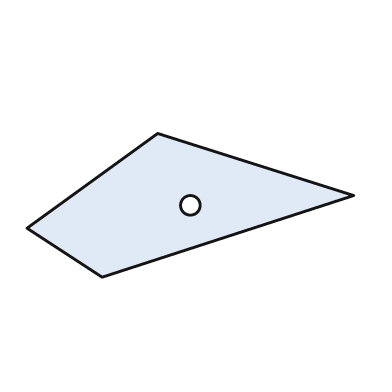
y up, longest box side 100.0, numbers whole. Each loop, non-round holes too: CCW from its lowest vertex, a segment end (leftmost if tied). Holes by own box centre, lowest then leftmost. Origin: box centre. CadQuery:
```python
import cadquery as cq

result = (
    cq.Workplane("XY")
    .moveTo(-27.0, -22.0)
    .lineTo(50.0, 3.0)
    .lineTo(-10.0, 22.0)
    .lineTo(-50.0, -7.0)
    .close()
    .moveTo(0.0, 0.0)
    .circle(3.0)
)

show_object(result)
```